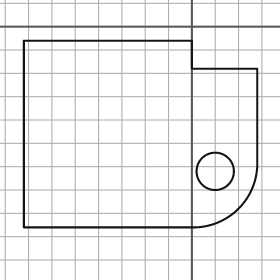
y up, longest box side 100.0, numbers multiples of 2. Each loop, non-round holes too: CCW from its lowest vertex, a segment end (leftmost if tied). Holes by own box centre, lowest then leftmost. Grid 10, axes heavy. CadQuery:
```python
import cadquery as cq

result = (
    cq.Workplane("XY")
    .moveTo(-72.0, -86.0)
    .lineTo(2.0, -86.0)
    .threePointArc((20.0, -78.0), (28.0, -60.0))
    .lineTo(28.0, -18.0)
    .lineTo(0.0, -18.0)
    .lineTo(0.0, -6.0)
    .lineTo(-72.0, -6.0)
    .close()
    .moveTo(10.0, -62.0)
    .circle(8.0)
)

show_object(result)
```